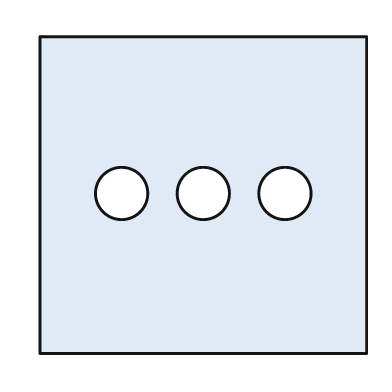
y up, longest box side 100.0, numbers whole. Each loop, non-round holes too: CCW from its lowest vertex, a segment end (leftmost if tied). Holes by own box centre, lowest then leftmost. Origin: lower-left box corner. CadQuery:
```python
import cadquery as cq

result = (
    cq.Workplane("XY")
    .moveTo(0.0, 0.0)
    .lineTo(100.0, 0.0)
    .lineTo(100.0, 97.0)
    .lineTo(0.0, 97.0)
    .close()
    .moveTo(25.0, 49.0)
    .circle(8.0)
    .moveTo(50.0, 49.0)
    .circle(8.0)
    .moveTo(75.0, 49.0)
    .circle(8.0)
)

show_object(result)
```